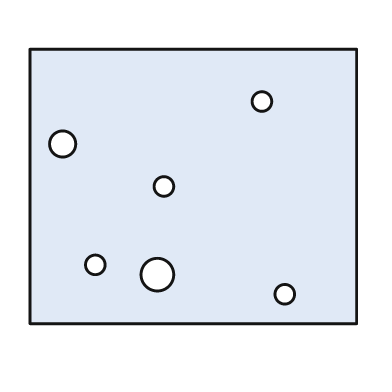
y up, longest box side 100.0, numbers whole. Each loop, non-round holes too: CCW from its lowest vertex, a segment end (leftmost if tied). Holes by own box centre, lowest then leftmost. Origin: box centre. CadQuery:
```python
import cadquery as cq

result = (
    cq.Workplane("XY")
    .moveTo(-50.0, -42.0)
    .lineTo(50.0, -42.0)
    .lineTo(50.0, 42.0)
    .lineTo(-50.0, 42.0)
    .close()
    .moveTo(28.0, -33.0)
    .circle(3.0)
    .moveTo(-11.0, -27.0)
    .circle(5.0)
    .moveTo(-30.0, -24.0)
    .circle(3.0)
    .moveTo(-9.0, 0.0)
    .circle(3.0)
    .moveTo(-40.0, 13.0)
    .circle(4.0)
    .moveTo(21.0, 26.0)
    .circle(3.0)
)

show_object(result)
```